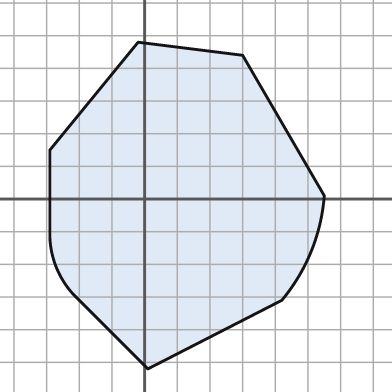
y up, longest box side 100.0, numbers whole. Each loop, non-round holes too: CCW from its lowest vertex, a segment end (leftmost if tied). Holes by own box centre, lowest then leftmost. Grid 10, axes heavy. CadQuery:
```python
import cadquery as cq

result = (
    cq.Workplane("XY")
    .moveTo(1.0, -52.0)
    .lineTo(42.0, -31.0)
    .threePointArc((51.0, -16.0), (55.0, 1.0))
    .lineTo(30.0, 44.0)
    .lineTo(-2.0, 48.0)
    .lineTo(-29.0, 15.0)
    .lineTo(-29.0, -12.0)
    .threePointArc((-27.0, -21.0), (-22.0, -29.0))
    .close()
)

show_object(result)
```